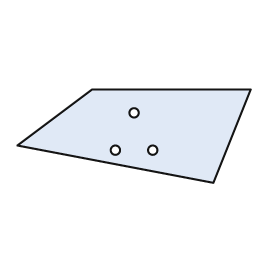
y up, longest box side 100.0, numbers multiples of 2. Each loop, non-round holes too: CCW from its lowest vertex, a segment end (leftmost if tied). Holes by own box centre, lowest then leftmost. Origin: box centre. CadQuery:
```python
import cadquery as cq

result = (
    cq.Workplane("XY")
    .moveTo(34.0, -20.0)
    .lineTo(50.0, 20.0)
    .lineTo(-18.0, 20.0)
    .lineTo(-50.0, -4.0)
    .close()
    .moveTo(-8.0, -6.0)
    .circle(2.0)
    .moveTo(8.0, -6.0)
    .circle(2.0)
    .moveTo(0.0, 10.0)
    .circle(2.0)
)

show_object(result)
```